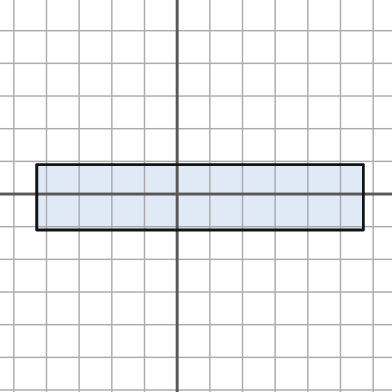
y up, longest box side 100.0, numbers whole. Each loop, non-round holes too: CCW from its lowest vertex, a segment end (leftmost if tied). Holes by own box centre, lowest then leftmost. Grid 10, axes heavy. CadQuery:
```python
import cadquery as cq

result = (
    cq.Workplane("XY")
    .moveTo(-43.0, -11.0)
    .lineTo(57.0, -11.0)
    .lineTo(57.0, 9.0)
    .lineTo(-43.0, 9.0)
    .close()
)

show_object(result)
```